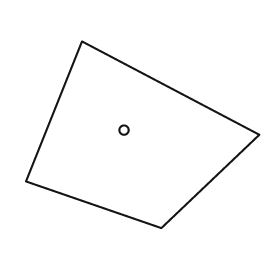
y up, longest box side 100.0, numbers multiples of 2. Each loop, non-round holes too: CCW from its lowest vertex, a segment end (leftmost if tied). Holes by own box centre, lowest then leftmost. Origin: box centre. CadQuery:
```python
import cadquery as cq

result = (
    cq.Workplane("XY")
    .moveTo(8.0, -40.0)
    .lineTo(50.0, 0.0)
    .lineTo(-26.0, 40.0)
    .lineTo(-50.0, -20.0)
    .close()
    .moveTo(-8.0, 2.0)
    .circle(2.0)
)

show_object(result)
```